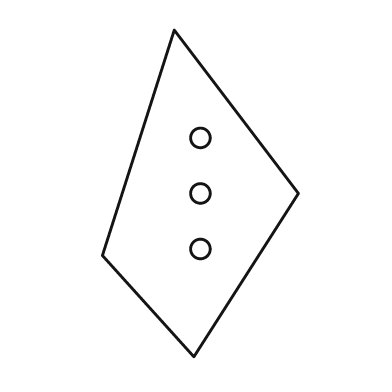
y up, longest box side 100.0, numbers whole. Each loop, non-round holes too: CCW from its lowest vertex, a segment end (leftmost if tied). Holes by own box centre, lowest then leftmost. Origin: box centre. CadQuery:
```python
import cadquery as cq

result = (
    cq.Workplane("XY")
    .moveTo(-2.0, -50.0)
    .lineTo(30.0, 0.0)
    .lineTo(-8.0, 50.0)
    .lineTo(-30.0, -19.0)
    .close()
    .moveTo(0.0, -17.0)
    .circle(3.0)
    .moveTo(0.0, 0.0)
    .circle(3.0)
    .moveTo(0.0, 17.0)
    .circle(3.0)
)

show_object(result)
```